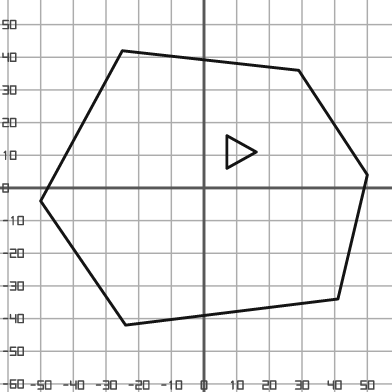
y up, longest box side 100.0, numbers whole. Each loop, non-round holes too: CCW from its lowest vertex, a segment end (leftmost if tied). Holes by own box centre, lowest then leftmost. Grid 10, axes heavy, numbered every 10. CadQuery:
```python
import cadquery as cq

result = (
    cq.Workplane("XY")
    .moveTo(-24.0, -42.0)
    .lineTo(41.0, -34.0)
    .lineTo(50.0, 4.0)
    .lineTo(29.0, 36.0)
    .lineTo(-25.0, 42.0)
    .lineTo(-50.0, -4.0)
    .close()
    .moveTo(7.0, 6.0)
    .lineTo(16.0, 11.0)
    .lineTo(7.0, 16.0)
    .close()
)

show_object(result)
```